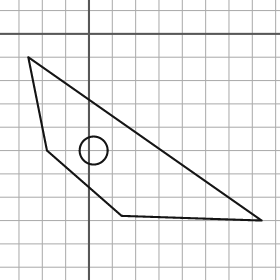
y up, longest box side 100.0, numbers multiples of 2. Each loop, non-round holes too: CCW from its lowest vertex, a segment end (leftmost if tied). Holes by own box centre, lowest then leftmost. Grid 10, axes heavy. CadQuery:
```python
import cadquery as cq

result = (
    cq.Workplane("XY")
    .moveTo(74.0, -80.0)
    .lineTo(-26.0, -10.0)
    .lineTo(-18.0, -50.0)
    .lineTo(14.0, -78.0)
    .close()
    .moveTo(2.0, -50.0)
    .circle(6.0)
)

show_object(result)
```